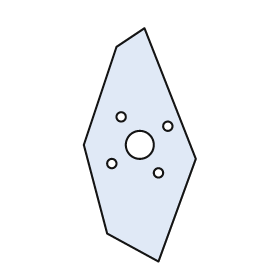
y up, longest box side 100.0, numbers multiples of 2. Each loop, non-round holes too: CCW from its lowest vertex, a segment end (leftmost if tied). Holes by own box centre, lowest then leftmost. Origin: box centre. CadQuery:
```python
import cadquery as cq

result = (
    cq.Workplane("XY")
    .moveTo(8.0, -50.0)
    .lineTo(24.0, -6.0)
    .lineTo(2.0, 50.0)
    .lineTo(-10.0, 42.0)
    .lineTo(-24.0, 0.0)
    .lineTo(-14.0, -38.0)
    .close()
    .moveTo(8.0, -12.0)
    .circle(2.0)
    .moveTo(-12.0, -8.0)
    .circle(2.0)
    .moveTo(0.0, 0.0)
    .circle(6.0)
    .moveTo(12.0, 8.0)
    .circle(2.0)
    .moveTo(-8.0, 12.0)
    .circle(2.0)
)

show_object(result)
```